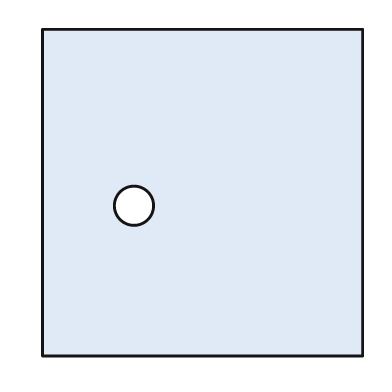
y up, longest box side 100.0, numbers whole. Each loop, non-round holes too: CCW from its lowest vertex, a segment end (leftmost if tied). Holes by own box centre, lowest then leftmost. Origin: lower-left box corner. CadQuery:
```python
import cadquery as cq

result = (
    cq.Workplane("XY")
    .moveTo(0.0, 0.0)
    .lineTo(98.0, 0.0)
    .lineTo(98.0, 100.0)
    .lineTo(0.0, 100.0)
    .close()
    .moveTo(28.0, 46.0)
    .circle(6.0)
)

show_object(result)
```